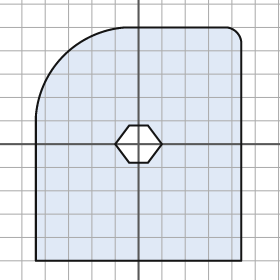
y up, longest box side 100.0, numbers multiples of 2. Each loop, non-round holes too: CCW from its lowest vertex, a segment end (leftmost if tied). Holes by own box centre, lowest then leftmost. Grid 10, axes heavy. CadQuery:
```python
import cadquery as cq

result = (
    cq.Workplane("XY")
    .moveTo(-44.0, -50.0)
    .lineTo(44.0, -50.0)
    .lineTo(44.0, 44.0)
    .threePointArc((42.0, 48.0), (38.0, 50.0))
    .lineTo(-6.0, 50.0)
    .threePointArc((-32.0, 38.0), (-44.0, 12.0))
    .close()
    .moveTo(-4.0, -8.0)
    .lineTo(4.0, -8.0)
    .lineTo(10.0, 0.0)
    .lineTo(4.0, 8.0)
    .lineTo(-4.0, 8.0)
    .lineTo(-10.0, 0.0)
    .close()
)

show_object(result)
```